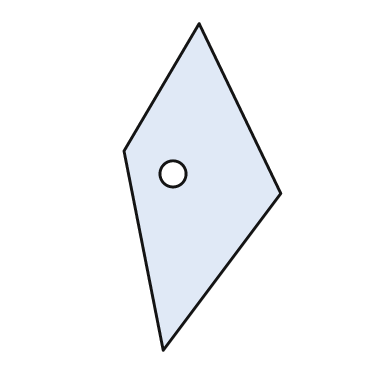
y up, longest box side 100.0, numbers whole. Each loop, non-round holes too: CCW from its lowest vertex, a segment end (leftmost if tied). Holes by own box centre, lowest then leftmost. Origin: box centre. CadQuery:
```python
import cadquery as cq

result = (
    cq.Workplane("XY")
    .moveTo(-12.0, -50.0)
    .lineTo(24.0, -2.0)
    .lineTo(-1.0, 50.0)
    .lineTo(-24.0, 11.0)
    .close()
    .moveTo(-9.0, 4.0)
    .circle(4.0)
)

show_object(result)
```